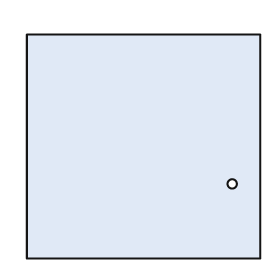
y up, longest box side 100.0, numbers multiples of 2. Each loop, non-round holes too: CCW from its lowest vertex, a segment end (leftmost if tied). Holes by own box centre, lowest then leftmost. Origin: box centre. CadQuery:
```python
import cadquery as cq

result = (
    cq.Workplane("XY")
    .moveTo(-50.0, -48.0)
    .lineTo(50.0, -48.0)
    .lineTo(50.0, 48.0)
    .lineTo(-50.0, 48.0)
    .close()
    .moveTo(38.0, -16.0)
    .circle(2.0)
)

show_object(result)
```